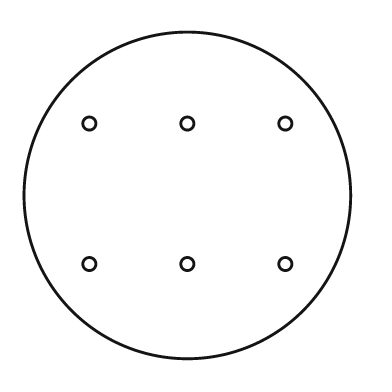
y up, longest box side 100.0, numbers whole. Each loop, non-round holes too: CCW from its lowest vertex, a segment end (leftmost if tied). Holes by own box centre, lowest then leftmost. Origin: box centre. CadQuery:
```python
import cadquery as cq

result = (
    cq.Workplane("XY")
    .moveTo(0.0, 0.0)
    .circle(50.0)
    .moveTo(-30.0, -21.0)
    .circle(2.0)
    .moveTo(0.0, -21.0)
    .circle(2.0)
    .moveTo(30.0, -21.0)
    .circle(2.0)
    .moveTo(-30.0, 22.0)
    .circle(2.0)
    .moveTo(0.0, 22.0)
    .circle(2.0)
    .moveTo(30.0, 22.0)
    .circle(2.0)
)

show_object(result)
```